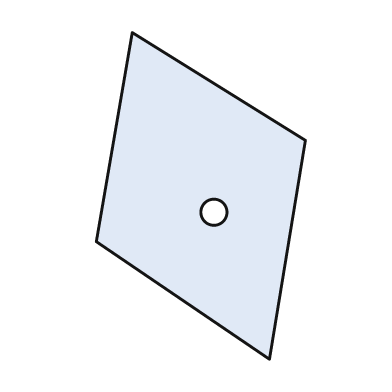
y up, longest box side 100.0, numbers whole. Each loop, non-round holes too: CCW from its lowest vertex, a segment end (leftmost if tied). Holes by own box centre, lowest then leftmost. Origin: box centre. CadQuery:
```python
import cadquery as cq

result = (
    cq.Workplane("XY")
    .moveTo(21.0, -50.0)
    .lineTo(32.0, 17.0)
    .lineTo(-21.0, 50.0)
    .lineTo(-32.0, -14.0)
    .close()
    .moveTo(4.0, -5.0)
    .circle(4.0)
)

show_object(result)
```